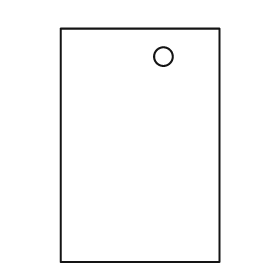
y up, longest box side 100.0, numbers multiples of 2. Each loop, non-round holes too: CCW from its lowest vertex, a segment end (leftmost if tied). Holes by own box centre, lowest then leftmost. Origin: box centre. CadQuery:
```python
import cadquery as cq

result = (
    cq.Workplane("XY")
    .moveTo(-34.0, -50.0)
    .lineTo(34.0, -50.0)
    .lineTo(34.0, 50.0)
    .lineTo(-34.0, 50.0)
    .close()
    .moveTo(10.0, 38.0)
    .circle(4.0)
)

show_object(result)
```